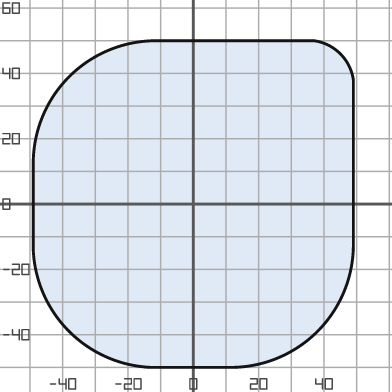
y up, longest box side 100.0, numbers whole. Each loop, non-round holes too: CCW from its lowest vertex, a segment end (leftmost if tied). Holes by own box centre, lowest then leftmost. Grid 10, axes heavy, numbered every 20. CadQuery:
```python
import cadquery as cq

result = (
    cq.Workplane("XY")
    .moveTo(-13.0, -50.0)
    .lineTo(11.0, -50.0)
    .threePointArc((38.0, -39.0), (49.0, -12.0))
    .lineTo(49.0, 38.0)
    .threePointArc((45.0, 46.0), (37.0, 50.0))
    .lineTo(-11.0, 50.0)
    .threePointArc((-38.0, 39.0), (-49.0, 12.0))
    .lineTo(-49.0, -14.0)
    .threePointArc((-38.0, -39.0), (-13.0, -50.0))
    .close()
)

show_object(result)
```